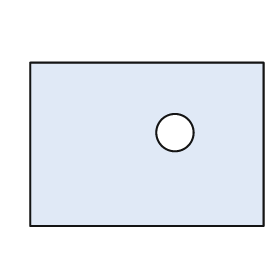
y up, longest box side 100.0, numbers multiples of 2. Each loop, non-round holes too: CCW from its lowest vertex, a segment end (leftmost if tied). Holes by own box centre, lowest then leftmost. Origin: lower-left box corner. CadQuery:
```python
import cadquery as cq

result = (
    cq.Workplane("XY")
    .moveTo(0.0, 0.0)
    .lineTo(100.0, 0.0)
    .lineTo(100.0, 70.0)
    .lineTo(0.0, 70.0)
    .close()
    .moveTo(62.0, 40.0)
    .circle(8.0)
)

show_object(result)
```